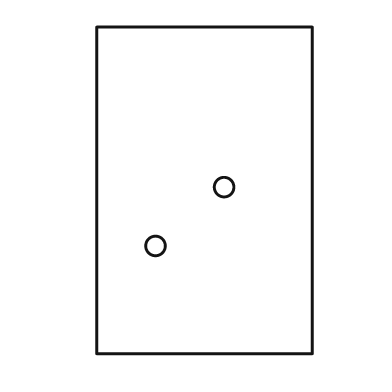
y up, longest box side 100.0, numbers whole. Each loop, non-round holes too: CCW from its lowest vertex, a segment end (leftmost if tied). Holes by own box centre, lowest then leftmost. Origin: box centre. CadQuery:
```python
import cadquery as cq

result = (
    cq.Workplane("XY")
    .moveTo(-33.0, -50.0)
    .lineTo(33.0, -50.0)
    .lineTo(33.0, 50.0)
    .lineTo(-33.0, 50.0)
    .close()
    .moveTo(-15.0, -17.0)
    .circle(3.0)
    .moveTo(6.0, 1.0)
    .circle(3.0)
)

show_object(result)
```